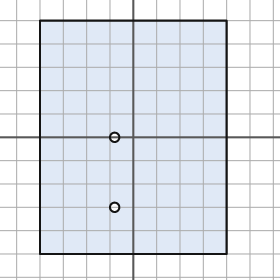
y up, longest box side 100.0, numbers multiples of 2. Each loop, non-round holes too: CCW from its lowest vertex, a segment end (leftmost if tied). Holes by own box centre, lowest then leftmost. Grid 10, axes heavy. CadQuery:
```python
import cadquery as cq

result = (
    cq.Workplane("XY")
    .moveTo(-40.0, -50.0)
    .lineTo(40.0, -50.0)
    .lineTo(40.0, 50.0)
    .lineTo(-40.0, 50.0)
    .close()
    .moveTo(-8.0, -30.0)
    .circle(2.0)
    .moveTo(-8.0, 0.0)
    .circle(2.0)
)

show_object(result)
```